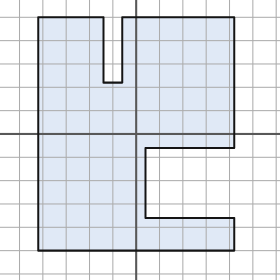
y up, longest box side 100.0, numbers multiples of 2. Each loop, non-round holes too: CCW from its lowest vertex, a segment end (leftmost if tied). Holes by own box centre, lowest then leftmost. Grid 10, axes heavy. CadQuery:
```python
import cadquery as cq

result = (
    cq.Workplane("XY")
    .moveTo(-42.0, -50.0)
    .lineTo(42.0, -50.0)
    .lineTo(42.0, -36.0)
    .lineTo(4.0, -36.0)
    .lineTo(4.0, -6.0)
    .lineTo(42.0, -6.0)
    .lineTo(42.0, 50.0)
    .lineTo(-6.0, 50.0)
    .lineTo(-6.0, 22.0)
    .lineTo(-14.0, 22.0)
    .lineTo(-14.0, 50.0)
    .lineTo(-42.0, 50.0)
    .close()
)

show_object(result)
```